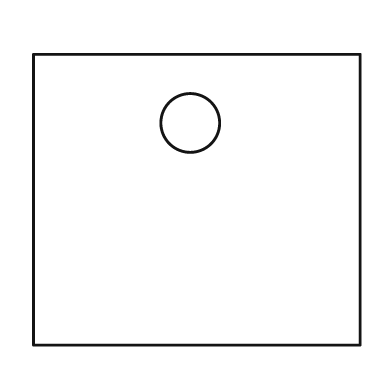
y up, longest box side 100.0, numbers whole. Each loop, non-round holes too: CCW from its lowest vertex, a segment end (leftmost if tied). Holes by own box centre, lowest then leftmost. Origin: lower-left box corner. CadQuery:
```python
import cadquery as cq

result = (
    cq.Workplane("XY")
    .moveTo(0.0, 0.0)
    .lineTo(100.0, 0.0)
    .lineTo(100.0, 89.0)
    .lineTo(0.0, 89.0)
    .close()
    .moveTo(48.0, 68.0)
    .circle(9.0)
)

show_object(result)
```